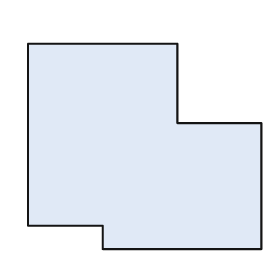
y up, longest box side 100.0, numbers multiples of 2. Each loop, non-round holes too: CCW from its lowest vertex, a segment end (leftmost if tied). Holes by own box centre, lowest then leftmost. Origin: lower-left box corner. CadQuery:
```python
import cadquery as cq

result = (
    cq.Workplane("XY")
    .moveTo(32.0, 0.0)
    .lineTo(100.0, 0.0)
    .lineTo(100.0, 54.0)
    .lineTo(64.0, 54.0)
    .lineTo(64.0, 88.0)
    .lineTo(0.0, 88.0)
    .lineTo(0.0, 10.0)
    .lineTo(32.0, 10.0)
    .close()
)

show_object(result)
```